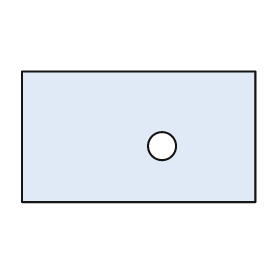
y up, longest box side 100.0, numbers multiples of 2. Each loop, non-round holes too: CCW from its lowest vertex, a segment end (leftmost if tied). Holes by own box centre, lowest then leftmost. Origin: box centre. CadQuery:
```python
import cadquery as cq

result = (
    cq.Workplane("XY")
    .moveTo(-50.0, -28.0)
    .lineTo(50.0, -28.0)
    .lineTo(50.0, 28.0)
    .lineTo(-50.0, 28.0)
    .close()
    .moveTo(10.0, -4.0)
    .circle(6.0)
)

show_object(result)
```